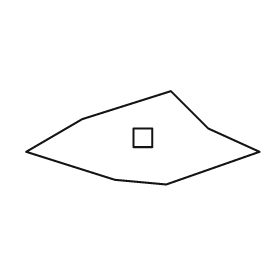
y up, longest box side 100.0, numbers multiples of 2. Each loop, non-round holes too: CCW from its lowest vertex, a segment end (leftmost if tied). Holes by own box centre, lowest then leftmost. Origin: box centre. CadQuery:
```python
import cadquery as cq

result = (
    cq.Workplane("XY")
    .moveTo(10.0, -20.0)
    .lineTo(50.0, -6.0)
    .lineTo(28.0, 4.0)
    .lineTo(12.0, 20.0)
    .lineTo(-26.0, 8.0)
    .lineTo(-50.0, -6.0)
    .lineTo(-12.0, -18.0)
    .close()
    .moveTo(-4.0, -4.0)
    .lineTo(4.0, -4.0)
    .lineTo(4.0, 4.0)
    .lineTo(-4.0, 4.0)
    .close()
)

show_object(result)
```